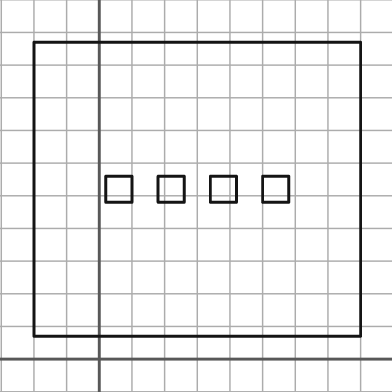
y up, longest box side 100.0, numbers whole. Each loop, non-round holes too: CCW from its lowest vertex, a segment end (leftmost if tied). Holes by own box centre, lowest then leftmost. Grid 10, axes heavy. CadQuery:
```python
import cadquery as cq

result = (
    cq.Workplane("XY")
    .moveTo(-20.0, 7.0)
    .lineTo(80.0, 7.0)
    .lineTo(80.0, 97.0)
    .lineTo(-20.0, 97.0)
    .close()
    .moveTo(2.0, 48.0)
    .lineTo(10.0, 48.0)
    .lineTo(10.0, 56.0)
    .lineTo(2.0, 56.0)
    .close()
    .moveTo(18.0, 48.0)
    .lineTo(26.0, 48.0)
    .lineTo(26.0, 56.0)
    .lineTo(18.0, 56.0)
    .close()
    .moveTo(34.0, 48.0)
    .lineTo(42.0, 48.0)
    .lineTo(42.0, 56.0)
    .lineTo(34.0, 56.0)
    .close()
    .moveTo(50.0, 48.0)
    .lineTo(58.0, 48.0)
    .lineTo(58.0, 56.0)
    .lineTo(50.0, 56.0)
    .close()
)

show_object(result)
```